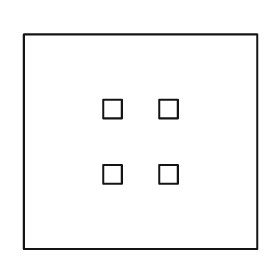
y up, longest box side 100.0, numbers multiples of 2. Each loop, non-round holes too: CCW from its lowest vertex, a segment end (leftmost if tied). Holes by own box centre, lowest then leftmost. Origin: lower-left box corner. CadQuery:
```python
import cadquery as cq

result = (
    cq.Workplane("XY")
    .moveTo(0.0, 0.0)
    .lineTo(100.0, 0.0)
    .lineTo(100.0, 92.0)
    .lineTo(0.0, 92.0)
    .close()
    .moveTo(34.0, 28.0)
    .lineTo(42.0, 28.0)
    .lineTo(42.0, 36.0)
    .lineTo(34.0, 36.0)
    .close()
    .moveTo(58.0, 28.0)
    .lineTo(66.0, 28.0)
    .lineTo(66.0, 36.0)
    .lineTo(58.0, 36.0)
    .close()
    .moveTo(34.0, 56.0)
    .lineTo(42.0, 56.0)
    .lineTo(42.0, 64.0)
    .lineTo(34.0, 64.0)
    .close()
    .moveTo(58.0, 56.0)
    .lineTo(66.0, 56.0)
    .lineTo(66.0, 64.0)
    .lineTo(58.0, 64.0)
    .close()
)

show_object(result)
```